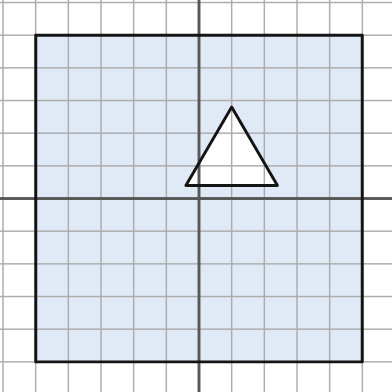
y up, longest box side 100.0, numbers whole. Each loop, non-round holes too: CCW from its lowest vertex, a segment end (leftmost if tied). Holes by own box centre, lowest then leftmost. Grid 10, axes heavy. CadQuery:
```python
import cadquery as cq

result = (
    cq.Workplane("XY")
    .moveTo(-50.0, -50.0)
    .lineTo(50.0, -50.0)
    .lineTo(50.0, 50.0)
    .lineTo(-50.0, 50.0)
    .close()
    .moveTo(-4.0, 4.0)
    .lineTo(24.0, 4.0)
    .lineTo(10.0, 28.0)
    .close()
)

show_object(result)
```